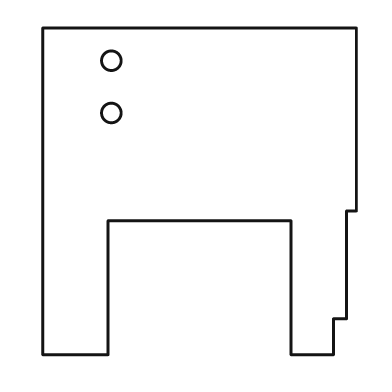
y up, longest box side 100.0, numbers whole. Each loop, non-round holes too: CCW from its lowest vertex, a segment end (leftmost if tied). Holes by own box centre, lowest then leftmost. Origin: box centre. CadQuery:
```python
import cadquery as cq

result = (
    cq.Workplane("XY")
    .moveTo(-48.0, -50.0)
    .lineTo(-28.0, -50.0)
    .lineTo(-28.0, -9.0)
    .lineTo(28.0, -9.0)
    .lineTo(28.0, -50.0)
    .lineTo(41.0, -50.0)
    .lineTo(41.0, -39.0)
    .lineTo(45.0, -39.0)
    .lineTo(45.0, -6.0)
    .lineTo(48.0, -6.0)
    .lineTo(48.0, 50.0)
    .lineTo(-48.0, 50.0)
    .close()
    .moveTo(-27.0, 24.0)
    .circle(3.0)
    .moveTo(-27.0, 40.0)
    .circle(3.0)
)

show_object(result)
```